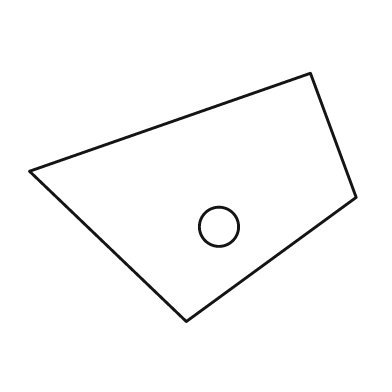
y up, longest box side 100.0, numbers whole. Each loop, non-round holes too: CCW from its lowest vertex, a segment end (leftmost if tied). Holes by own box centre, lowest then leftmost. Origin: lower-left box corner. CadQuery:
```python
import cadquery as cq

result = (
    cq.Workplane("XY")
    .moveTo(48.0, 0.0)
    .lineTo(100.0, 38.0)
    .lineTo(86.0, 76.0)
    .lineTo(0.0, 46.0)
    .close()
    .moveTo(58.0, 29.0)
    .circle(6.0)
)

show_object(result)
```